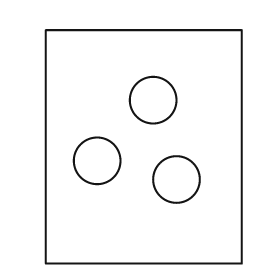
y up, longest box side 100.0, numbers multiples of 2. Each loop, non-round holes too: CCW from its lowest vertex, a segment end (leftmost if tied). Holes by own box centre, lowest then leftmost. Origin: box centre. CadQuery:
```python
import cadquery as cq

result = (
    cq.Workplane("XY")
    .moveTo(-42.0, -50.0)
    .lineTo(42.0, -50.0)
    .lineTo(42.0, 50.0)
    .lineTo(-42.0, 50.0)
    .close()
    .moveTo(14.0, -14.0)
    .circle(10.0)
    .moveTo(-20.0, -6.0)
    .circle(10.0)
    .moveTo(4.0, 20.0)
    .circle(10.0)
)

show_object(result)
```